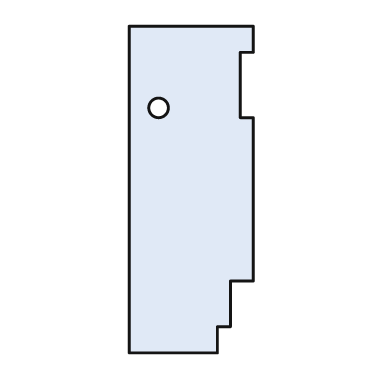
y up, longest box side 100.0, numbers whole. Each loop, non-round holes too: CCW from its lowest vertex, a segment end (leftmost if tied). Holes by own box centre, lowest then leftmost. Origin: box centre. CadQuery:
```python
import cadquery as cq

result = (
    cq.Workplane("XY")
    .moveTo(-19.0, -50.0)
    .lineTo(8.0, -50.0)
    .lineTo(8.0, -42.0)
    .lineTo(12.0, -42.0)
    .lineTo(12.0, -28.0)
    .lineTo(19.0, -28.0)
    .lineTo(19.0, 22.0)
    .lineTo(15.0, 22.0)
    .lineTo(15.0, 42.0)
    .lineTo(19.0, 42.0)
    .lineTo(19.0, 50.0)
    .lineTo(-19.0, 50.0)
    .close()
    .moveTo(-10.0, 25.0)
    .circle(3.0)
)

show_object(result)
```